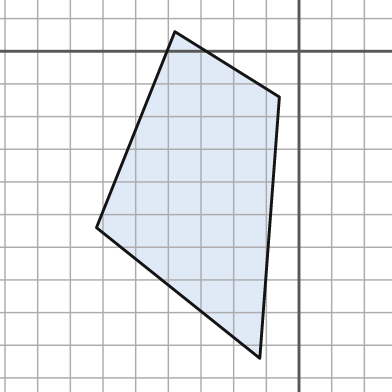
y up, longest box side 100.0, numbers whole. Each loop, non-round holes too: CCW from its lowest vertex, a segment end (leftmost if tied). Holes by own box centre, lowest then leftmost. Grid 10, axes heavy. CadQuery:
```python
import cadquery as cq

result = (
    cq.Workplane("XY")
    .moveTo(-12.0, -94.0)
    .lineTo(-6.0, -14.0)
    .lineTo(-38.0, 6.0)
    .lineTo(-62.0, -54.0)
    .close()
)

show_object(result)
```